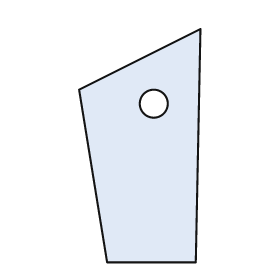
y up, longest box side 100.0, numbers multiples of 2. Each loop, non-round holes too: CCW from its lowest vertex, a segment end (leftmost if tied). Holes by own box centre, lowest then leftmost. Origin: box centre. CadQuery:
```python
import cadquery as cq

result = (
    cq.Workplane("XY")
    .moveTo(-14.0, -50.0)
    .lineTo(24.0, -50.0)
    .lineTo(26.0, 50.0)
    .lineTo(-26.0, 24.0)
    .close()
    .moveTo(6.0, 18.0)
    .circle(6.0)
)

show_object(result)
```